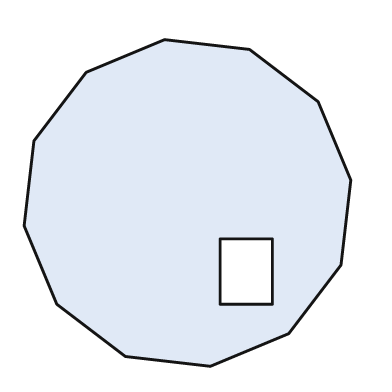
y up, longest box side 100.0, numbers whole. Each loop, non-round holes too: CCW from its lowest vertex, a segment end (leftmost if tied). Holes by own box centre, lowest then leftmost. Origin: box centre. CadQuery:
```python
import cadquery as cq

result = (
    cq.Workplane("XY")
    .moveTo(7.0, -50.0)
    .lineTo(31.0, -40.0)
    .lineTo(47.0, -19.0)
    .lineTo(50.0, 7.0)
    .lineTo(40.0, 31.0)
    .lineTo(19.0, 47.0)
    .lineTo(-7.0, 50.0)
    .lineTo(-31.0, 40.0)
    .lineTo(-47.0, 19.0)
    .lineTo(-50.0, -7.0)
    .lineTo(-40.0, -31.0)
    .lineTo(-19.0, -47.0)
    .close()
    .moveTo(10.0, -31.0)
    .lineTo(26.0, -31.0)
    .lineTo(26.0, -11.0)
    .lineTo(10.0, -11.0)
    .close()
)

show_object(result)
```